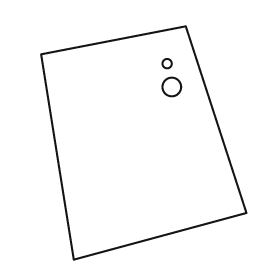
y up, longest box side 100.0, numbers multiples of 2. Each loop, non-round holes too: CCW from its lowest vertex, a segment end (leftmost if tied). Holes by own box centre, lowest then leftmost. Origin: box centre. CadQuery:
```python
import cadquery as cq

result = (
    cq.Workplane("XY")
    .moveTo(-30.0, -50.0)
    .lineTo(44.0, -30.0)
    .lineTo(18.0, 50.0)
    .lineTo(-44.0, 38.0)
    .close()
    .moveTo(12.0, 24.0)
    .circle(4.0)
    .moveTo(10.0, 34.0)
    .circle(2.0)
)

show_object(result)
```